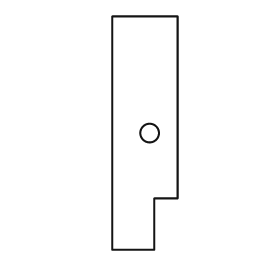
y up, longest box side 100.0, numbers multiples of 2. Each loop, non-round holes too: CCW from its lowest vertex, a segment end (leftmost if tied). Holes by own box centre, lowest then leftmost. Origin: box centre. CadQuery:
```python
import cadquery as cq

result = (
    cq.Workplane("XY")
    .moveTo(-14.0, -50.0)
    .lineTo(4.0, -50.0)
    .lineTo(4.0, -28.0)
    .lineTo(14.0, -28.0)
    .lineTo(14.0, 50.0)
    .lineTo(-14.0, 50.0)
    .close()
    .moveTo(2.0, 0.0)
    .circle(4.0)
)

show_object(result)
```